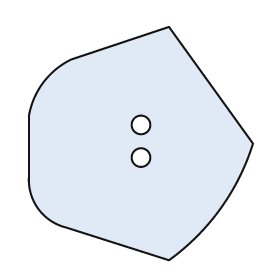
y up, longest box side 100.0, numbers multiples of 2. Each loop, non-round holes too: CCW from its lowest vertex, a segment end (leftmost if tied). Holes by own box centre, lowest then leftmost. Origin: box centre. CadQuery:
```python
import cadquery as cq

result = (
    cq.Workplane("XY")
    .moveTo(12.0, -50.0)
    .threePointArc((34.0, -28.0), (48.0, 0.0))
    .lineTo(12.0, 50.0)
    .lineTo(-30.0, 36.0)
    .threePointArc((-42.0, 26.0), (-48.0, 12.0))
    .lineTo(-48.0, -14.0)
    .threePointArc((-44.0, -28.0), (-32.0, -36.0))
    .close()
    .moveTo(0.0, -6.0)
    .circle(4.0)
    .moveTo(0.0, 8.0)
    .circle(4.0)
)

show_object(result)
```